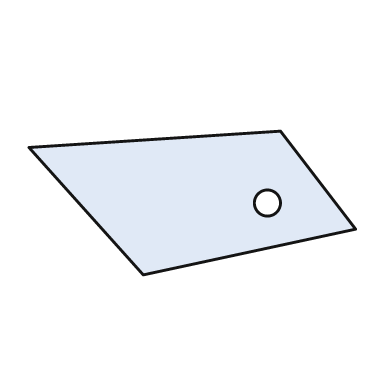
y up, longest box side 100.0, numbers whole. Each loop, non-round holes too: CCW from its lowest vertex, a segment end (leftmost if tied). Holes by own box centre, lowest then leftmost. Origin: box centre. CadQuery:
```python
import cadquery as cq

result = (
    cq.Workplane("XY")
    .moveTo(-15.0, -22.0)
    .lineTo(50.0, -8.0)
    .lineTo(27.0, 22.0)
    .lineTo(-50.0, 17.0)
    .close()
    .moveTo(23.0, 0.0)
    .circle(4.0)
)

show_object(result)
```